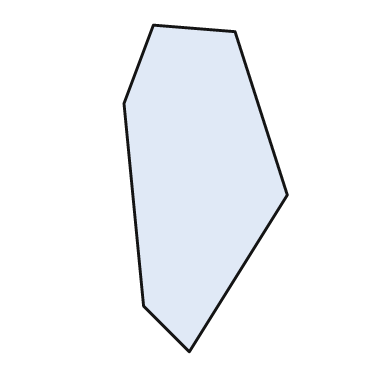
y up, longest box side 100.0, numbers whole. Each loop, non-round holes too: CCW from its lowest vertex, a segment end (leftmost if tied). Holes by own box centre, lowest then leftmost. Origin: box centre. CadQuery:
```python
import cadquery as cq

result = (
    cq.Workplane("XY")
    .moveTo(-5.0, -50.0)
    .lineTo(25.0, -2.0)
    .lineTo(9.0, 48.0)
    .lineTo(-16.0, 50.0)
    .lineTo(-25.0, 26.0)
    .lineTo(-19.0, -36.0)
    .close()
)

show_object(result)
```